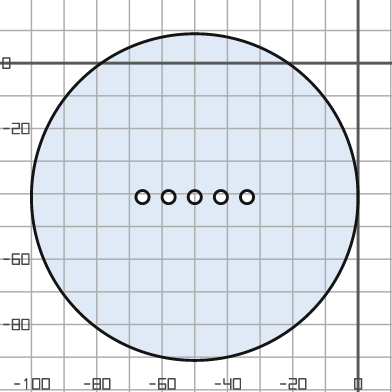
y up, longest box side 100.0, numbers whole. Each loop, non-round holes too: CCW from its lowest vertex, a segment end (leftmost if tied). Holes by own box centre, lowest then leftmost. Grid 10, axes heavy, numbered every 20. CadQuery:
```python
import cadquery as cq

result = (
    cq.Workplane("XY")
    .moveTo(-50.0, -41.0)
    .circle(50.0)
    .moveTo(-66.0, -41.0)
    .circle(2.0)
    .moveTo(-58.0, -41.0)
    .circle(2.0)
    .moveTo(-50.0, -41.0)
    .circle(2.0)
    .moveTo(-42.0, -41.0)
    .circle(2.0)
    .moveTo(-34.0, -41.0)
    .circle(2.0)
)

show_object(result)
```